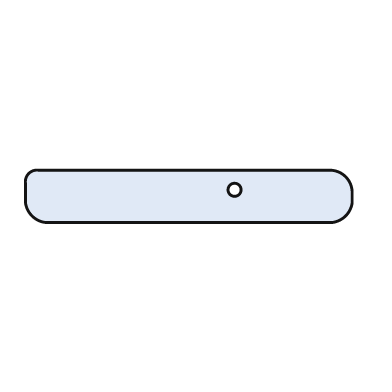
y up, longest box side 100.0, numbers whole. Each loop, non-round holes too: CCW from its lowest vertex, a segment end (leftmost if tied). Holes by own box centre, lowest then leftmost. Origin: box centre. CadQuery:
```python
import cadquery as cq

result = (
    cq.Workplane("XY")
    .moveTo(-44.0, -8.0)
    .lineTo(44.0, -8.0)
    .threePointArc((48.0, -6.0), (50.0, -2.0))
    .lineTo(50.0, 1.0)
    .threePointArc((48.0, 6.0), (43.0, 8.0))
    .lineTo(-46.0, 8.0)
    .threePointArc((-49.0, 7.0), (-50.0, 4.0))
    .lineTo(-50.0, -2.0)
    .threePointArc((-48.0, -6.0), (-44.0, -8.0))
    .close()
    .moveTo(14.0, 2.0)
    .circle(2.0)
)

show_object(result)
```